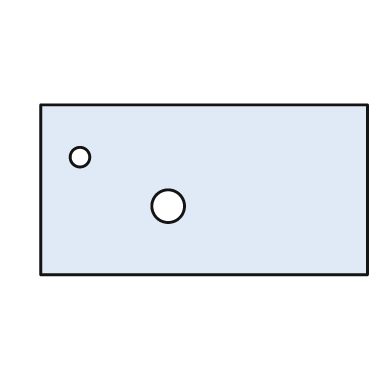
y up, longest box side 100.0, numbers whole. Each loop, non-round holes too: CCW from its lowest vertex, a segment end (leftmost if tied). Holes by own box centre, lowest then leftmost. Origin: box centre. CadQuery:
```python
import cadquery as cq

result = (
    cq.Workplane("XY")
    .moveTo(-50.0, -26.0)
    .lineTo(50.0, -26.0)
    .lineTo(50.0, 26.0)
    .lineTo(-50.0, 26.0)
    .close()
    .moveTo(-11.0, -5.0)
    .circle(5.0)
    .moveTo(-38.0, 10.0)
    .circle(3.0)
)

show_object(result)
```